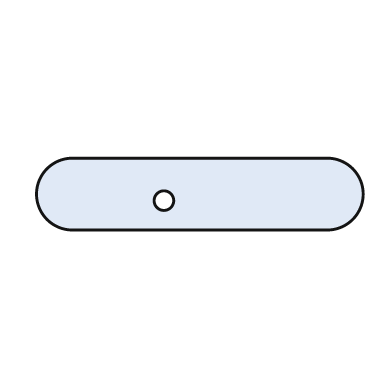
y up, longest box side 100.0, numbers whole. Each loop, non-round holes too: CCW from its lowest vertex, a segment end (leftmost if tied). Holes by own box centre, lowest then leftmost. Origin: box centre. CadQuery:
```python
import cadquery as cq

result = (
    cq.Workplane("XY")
    .moveTo(-39.0, -11.0)
    .lineTo(39.0, -11.0)
    .threePointArc((50.0, 0.0), (39.0, 11.0))
    .lineTo(-39.0, 11.0)
    .threePointArc((-50.0, 0.0), (-39.0, -11.0))
    .close()
    .moveTo(-11.0, -2.0)
    .circle(3.0)
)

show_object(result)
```